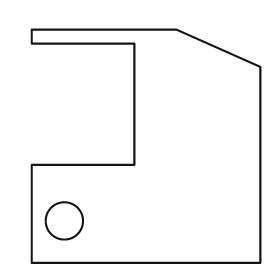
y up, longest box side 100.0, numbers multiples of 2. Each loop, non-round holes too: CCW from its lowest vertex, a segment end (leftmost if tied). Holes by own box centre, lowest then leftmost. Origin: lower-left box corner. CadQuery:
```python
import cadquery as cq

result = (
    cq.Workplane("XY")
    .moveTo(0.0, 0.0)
    .lineTo(98.0, 0.0)
    .lineTo(98.0, 84.0)
    .lineTo(62.0, 100.0)
    .lineTo(0.0, 100.0)
    .lineTo(0.0, 94.0)
    .lineTo(44.0, 94.0)
    .lineTo(44.0, 42.0)
    .lineTo(0.0, 42.0)
    .close()
    .moveTo(14.0, 18.0)
    .circle(8.0)
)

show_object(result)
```